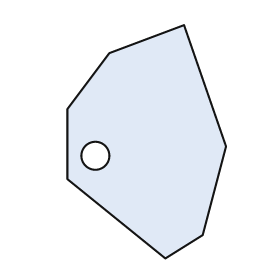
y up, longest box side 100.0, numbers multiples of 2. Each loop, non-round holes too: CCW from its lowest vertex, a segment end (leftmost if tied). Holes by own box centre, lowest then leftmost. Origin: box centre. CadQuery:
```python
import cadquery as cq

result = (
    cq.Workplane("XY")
    .moveTo(8.0, -50.0)
    .lineTo(24.0, -40.0)
    .lineTo(34.0, -2.0)
    .lineTo(16.0, 50.0)
    .lineTo(-16.0, 38.0)
    .lineTo(-34.0, 14.0)
    .lineTo(-34.0, -16.0)
    .close()
    .moveTo(-22.0, -6.0)
    .circle(6.0)
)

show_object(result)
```